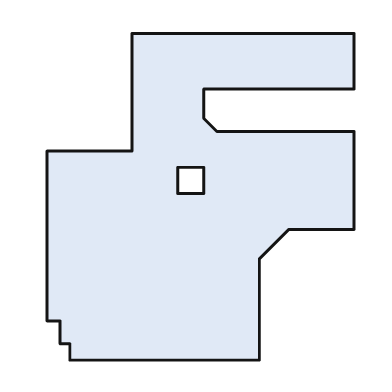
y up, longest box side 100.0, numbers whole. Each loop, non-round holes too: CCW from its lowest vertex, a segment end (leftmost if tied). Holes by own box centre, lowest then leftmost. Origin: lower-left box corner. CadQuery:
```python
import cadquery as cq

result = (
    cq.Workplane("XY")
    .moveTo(7.0, 0.0)
    .lineTo(65.0, 0.0)
    .lineTo(65.0, 31.0)
    .lineTo(74.0, 40.0)
    .lineTo(94.0, 40.0)
    .lineTo(94.0, 70.0)
    .lineTo(52.0, 70.0)
    .lineTo(48.0, 74.0)
    .lineTo(48.0, 83.0)
    .lineTo(94.0, 83.0)
    .lineTo(94.0, 100.0)
    .lineTo(26.0, 100.0)
    .lineTo(26.0, 64.0)
    .lineTo(0.0, 64.0)
    .lineTo(0.0, 12.0)
    .lineTo(4.0, 12.0)
    .lineTo(4.0, 5.0)
    .lineTo(7.0, 5.0)
    .close()
    .moveTo(40.0, 51.0)
    .lineTo(48.0, 51.0)
    .lineTo(48.0, 59.0)
    .lineTo(40.0, 59.0)
    .close()
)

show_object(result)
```